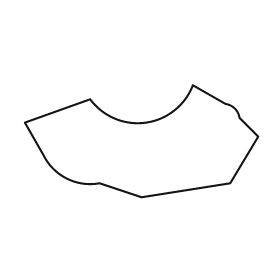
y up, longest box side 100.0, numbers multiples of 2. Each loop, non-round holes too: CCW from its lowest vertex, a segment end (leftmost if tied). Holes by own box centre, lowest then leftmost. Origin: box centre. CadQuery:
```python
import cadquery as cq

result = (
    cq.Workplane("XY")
    .moveTo(0.0, -24.0)
    .lineTo(38.0, -18.0)
    .lineTo(50.0, 2.0)
    .lineTo(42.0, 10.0)
    .threePointArc((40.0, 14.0), (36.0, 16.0))
    .lineTo(22.0, 24.0)
    .threePointArc((2.0, 8.0), (-22.0, 18.0))
    .lineTo(-50.0, 8.0)
    .lineTo(-42.0, -6.0)
    .threePointArc((-32.0, -16.0), (-18.0, -18.0))
    .close()
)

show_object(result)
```